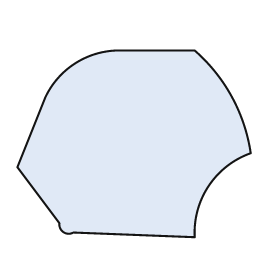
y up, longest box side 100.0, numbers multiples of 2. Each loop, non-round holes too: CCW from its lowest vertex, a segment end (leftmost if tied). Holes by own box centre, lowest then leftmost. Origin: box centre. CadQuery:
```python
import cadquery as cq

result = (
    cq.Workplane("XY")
    .moveTo(26.0, -40.0)
    .threePointArc((32.0, -18.0), (50.0, -4.0))
    .threePointArc((42.0, 20.0), (26.0, 40.0))
    .lineTo(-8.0, 40.0)
    .threePointArc((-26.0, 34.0), (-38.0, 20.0))
    .lineTo(-50.0, -10.0)
    .lineTo(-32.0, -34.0)
    .threePointArc((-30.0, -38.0), (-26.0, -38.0))
    .close()
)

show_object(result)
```